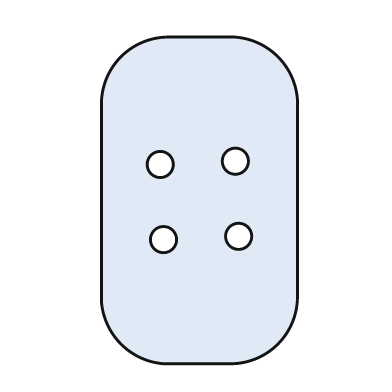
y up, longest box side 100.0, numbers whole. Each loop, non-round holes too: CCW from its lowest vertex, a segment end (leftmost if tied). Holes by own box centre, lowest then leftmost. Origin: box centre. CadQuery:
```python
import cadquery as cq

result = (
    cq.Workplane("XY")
    .moveTo(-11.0, -50.0)
    .lineTo(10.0, -50.0)
    .threePointArc((24.0, -44.0), (30.0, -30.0))
    .lineTo(30.0, 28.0)
    .threePointArc((24.0, 44.0), (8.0, 50.0))
    .lineTo(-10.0, 50.0)
    .threePointArc((-24.0, 44.0), (-30.0, 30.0))
    .lineTo(-30.0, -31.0)
    .threePointArc((-24.0, -44.0), (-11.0, -50.0))
    .close()
    .moveTo(-11.0, -12.0)
    .circle(4.0)
    .moveTo(12.0, -11.0)
    .circle(4.0)
    .moveTo(-12.0, 11.0)
    .circle(4.0)
    .moveTo(11.0, 12.0)
    .circle(4.0)
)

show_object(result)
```